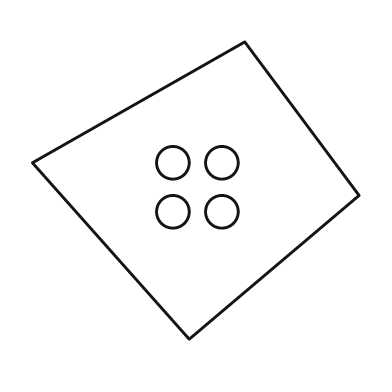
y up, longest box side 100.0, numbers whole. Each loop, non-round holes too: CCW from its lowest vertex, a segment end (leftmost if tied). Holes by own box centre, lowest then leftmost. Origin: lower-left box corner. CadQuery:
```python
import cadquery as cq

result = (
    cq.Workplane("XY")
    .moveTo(48.0, 0.0)
    .lineTo(100.0, 44.0)
    .lineTo(65.0, 91.0)
    .lineTo(0.0, 54.0)
    .close()
    .moveTo(43.0, 39.0)
    .circle(5.0)
    .moveTo(58.0, 39.0)
    .circle(5.0)
    .moveTo(43.0, 54.0)
    .circle(5.0)
    .moveTo(58.0, 54.0)
    .circle(5.0)
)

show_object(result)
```